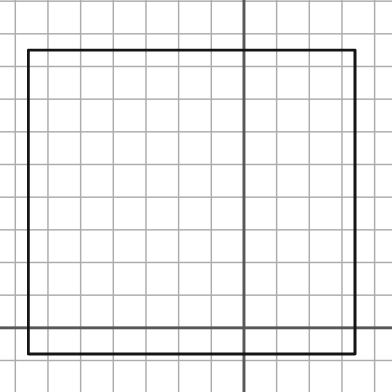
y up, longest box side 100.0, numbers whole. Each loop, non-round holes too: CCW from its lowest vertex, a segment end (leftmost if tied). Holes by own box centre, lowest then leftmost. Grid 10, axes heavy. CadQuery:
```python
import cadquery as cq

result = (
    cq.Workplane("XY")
    .moveTo(-66.0, -8.0)
    .lineTo(34.0, -8.0)
    .lineTo(34.0, 85.0)
    .lineTo(-66.0, 85.0)
    .close()
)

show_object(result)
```